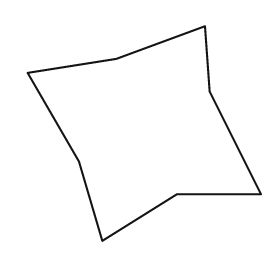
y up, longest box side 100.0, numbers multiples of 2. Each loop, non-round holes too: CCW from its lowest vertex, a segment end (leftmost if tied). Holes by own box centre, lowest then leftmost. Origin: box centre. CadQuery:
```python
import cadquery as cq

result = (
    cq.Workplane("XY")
    .moveTo(-18.0, -46.0)
    .lineTo(14.0, -26.0)
    .lineTo(50.0, -26.0)
    .lineTo(28.0, 18.0)
    .lineTo(26.0, 46.0)
    .lineTo(-12.0, 32.0)
    .lineTo(-50.0, 26.0)
    .lineTo(-28.0, -12.0)
    .close()
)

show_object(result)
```